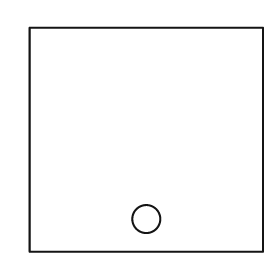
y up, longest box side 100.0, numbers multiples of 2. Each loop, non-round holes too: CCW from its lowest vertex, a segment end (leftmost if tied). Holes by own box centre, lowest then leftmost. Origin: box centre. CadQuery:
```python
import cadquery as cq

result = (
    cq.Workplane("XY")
    .moveTo(-50.0, -48.0)
    .lineTo(50.0, -48.0)
    .lineTo(50.0, 48.0)
    .lineTo(-50.0, 48.0)
    .close()
    .moveTo(0.0, -34.0)
    .circle(6.0)
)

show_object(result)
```